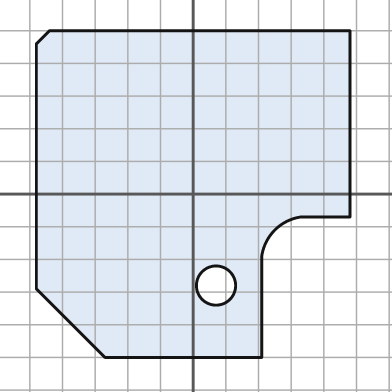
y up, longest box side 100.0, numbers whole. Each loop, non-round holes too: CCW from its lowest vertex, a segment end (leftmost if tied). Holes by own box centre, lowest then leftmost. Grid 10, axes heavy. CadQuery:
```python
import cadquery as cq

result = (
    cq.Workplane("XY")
    .moveTo(-27.0, -50.0)
    .lineTo(21.0, -50.0)
    .lineTo(21.0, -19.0)
    .threePointArc((25.0, -11.0), (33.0, -7.0))
    .lineTo(48.0, -7.0)
    .lineTo(48.0, 50.0)
    .lineTo(-44.0, 50.0)
    .lineTo(-48.0, 46.0)
    .lineTo(-48.0, -29.0)
    .close()
    .moveTo(7.0, -28.0)
    .circle(6.0)
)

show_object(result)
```